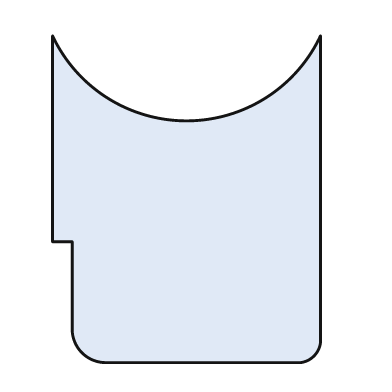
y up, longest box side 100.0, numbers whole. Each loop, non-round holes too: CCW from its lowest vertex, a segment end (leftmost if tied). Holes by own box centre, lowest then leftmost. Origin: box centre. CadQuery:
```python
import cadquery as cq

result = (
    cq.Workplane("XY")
    .moveTo(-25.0, -50.0)
    .lineTo(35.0, -50.0)
    .threePointArc((39.0, -48.0), (41.0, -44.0))
    .lineTo(41.0, 50.0)
    .threePointArc((0.0, 24.0), (-41.0, 50.0))
    .lineTo(-41.0, -13.0)
    .lineTo(-35.0, -13.0)
    .lineTo(-35.0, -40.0)
    .threePointArc((-32.0, -47.0), (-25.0, -50.0))
    .close()
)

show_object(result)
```